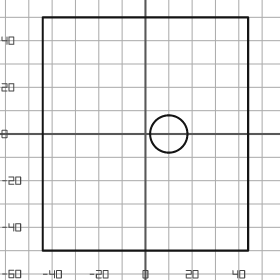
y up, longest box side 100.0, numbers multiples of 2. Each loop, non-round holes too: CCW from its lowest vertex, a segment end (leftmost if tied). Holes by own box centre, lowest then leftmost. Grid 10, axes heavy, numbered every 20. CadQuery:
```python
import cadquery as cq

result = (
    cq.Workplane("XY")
    .moveTo(-44.0, -50.0)
    .lineTo(44.0, -50.0)
    .lineTo(44.0, 50.0)
    .lineTo(-44.0, 50.0)
    .close()
    .moveTo(10.0, 0.0)
    .circle(8.0)
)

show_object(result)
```